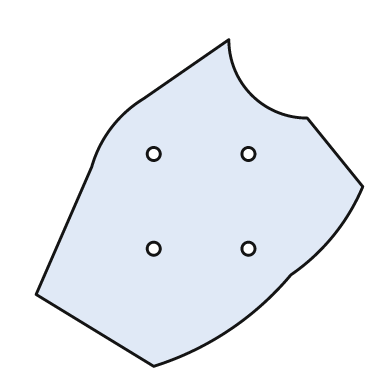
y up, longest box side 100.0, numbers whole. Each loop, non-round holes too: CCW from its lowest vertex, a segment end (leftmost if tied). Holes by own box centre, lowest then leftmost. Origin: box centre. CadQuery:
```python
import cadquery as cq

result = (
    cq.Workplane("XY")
    .moveTo(-14.0, -50.0)
    .threePointArc((9.0, -39.0), (28.0, -22.0))
    .threePointArc((41.0, -10.0), (50.0, 5.0))
    .lineTo(33.0, 26.0)
    .threePointArc((16.0, 33.0), (9.0, 50.0))
    .lineTo(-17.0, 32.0)
    .threePointArc((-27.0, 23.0), (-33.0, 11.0))
    .lineTo(-50.0, -28.0)
    .close()
    .moveTo(-14.0, -14.0)
    .circle(2.0)
    .moveTo(15.0, -14.0)
    .circle(2.0)
    .moveTo(-14.0, 15.0)
    .circle(2.0)
    .moveTo(15.0, 15.0)
    .circle(2.0)
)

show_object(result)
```